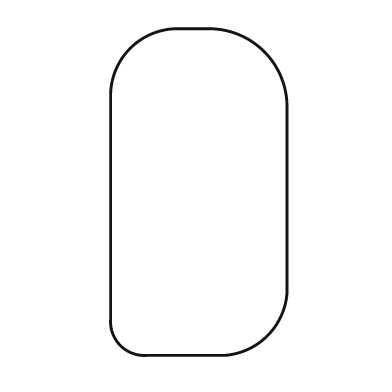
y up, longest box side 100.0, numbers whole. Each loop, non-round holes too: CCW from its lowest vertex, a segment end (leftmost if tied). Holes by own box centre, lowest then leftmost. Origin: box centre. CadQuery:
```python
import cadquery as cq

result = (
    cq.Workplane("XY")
    .moveTo(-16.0, -50.0)
    .lineTo(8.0, -50.0)
    .threePointArc((21.0, -44.0), (27.0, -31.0))
    .lineTo(27.0, 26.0)
    .threePointArc((20.0, 43.0), (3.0, 50.0))
    .lineTo(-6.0, 50.0)
    .threePointArc((-21.0, 44.0), (-27.0, 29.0))
    .lineTo(-27.0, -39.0)
    .threePointArc((-24.0, -47.0), (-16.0, -50.0))
    .close()
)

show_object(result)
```